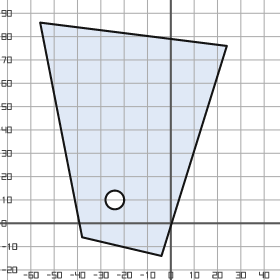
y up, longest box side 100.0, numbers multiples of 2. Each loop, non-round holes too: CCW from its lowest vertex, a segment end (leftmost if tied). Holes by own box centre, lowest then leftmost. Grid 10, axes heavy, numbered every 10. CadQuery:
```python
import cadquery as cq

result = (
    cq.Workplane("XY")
    .moveTo(-4.0, -14.0)
    .lineTo(24.0, 76.0)
    .lineTo(-56.0, 86.0)
    .lineTo(-38.0, -6.0)
    .close()
    .moveTo(-24.0, 10.0)
    .circle(4.0)
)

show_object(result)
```